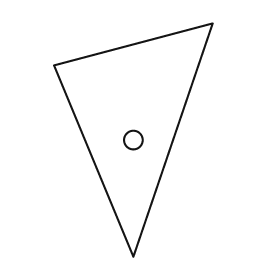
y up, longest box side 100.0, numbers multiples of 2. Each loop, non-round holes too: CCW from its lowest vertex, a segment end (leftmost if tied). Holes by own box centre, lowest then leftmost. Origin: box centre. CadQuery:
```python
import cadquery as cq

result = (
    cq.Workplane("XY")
    .moveTo(0.0, -50.0)
    .lineTo(34.0, 50.0)
    .lineTo(-34.0, 32.0)
    .close()
    .moveTo(0.0, 0.0)
    .circle(4.0)
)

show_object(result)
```